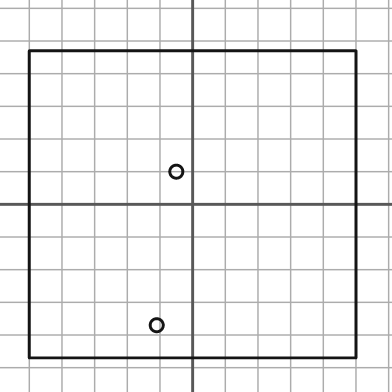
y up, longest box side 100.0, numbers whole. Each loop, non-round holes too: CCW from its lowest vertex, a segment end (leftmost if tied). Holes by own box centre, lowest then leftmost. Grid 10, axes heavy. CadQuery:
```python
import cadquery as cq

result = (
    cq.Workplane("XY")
    .moveTo(-50.0, -47.0)
    .lineTo(50.0, -47.0)
    .lineTo(50.0, 47.0)
    .lineTo(-50.0, 47.0)
    .close()
    .moveTo(-11.0, -37.0)
    .circle(2.0)
    .moveTo(-5.0, 10.0)
    .circle(2.0)
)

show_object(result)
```